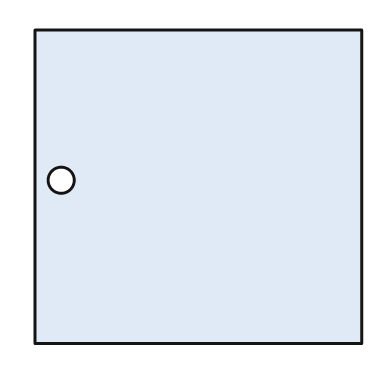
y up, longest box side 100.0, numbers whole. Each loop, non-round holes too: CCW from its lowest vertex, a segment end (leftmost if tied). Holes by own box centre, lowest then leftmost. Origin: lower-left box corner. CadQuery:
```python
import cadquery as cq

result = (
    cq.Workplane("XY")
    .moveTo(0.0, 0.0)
    .lineTo(100.0, 0.0)
    .lineTo(100.0, 96.0)
    .lineTo(0.0, 96.0)
    .close()
    .moveTo(8.0, 50.0)
    .circle(4.0)
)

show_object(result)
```